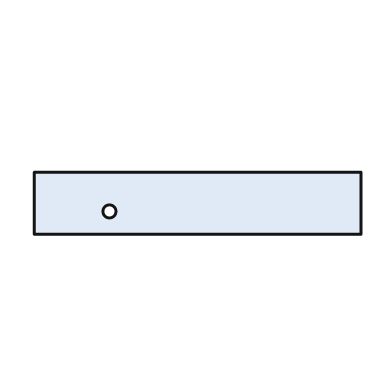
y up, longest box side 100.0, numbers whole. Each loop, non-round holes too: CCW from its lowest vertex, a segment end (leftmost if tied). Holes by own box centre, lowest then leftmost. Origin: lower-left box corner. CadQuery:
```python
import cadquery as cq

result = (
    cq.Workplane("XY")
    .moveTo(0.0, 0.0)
    .lineTo(100.0, 0.0)
    .lineTo(100.0, 19.0)
    .lineTo(0.0, 19.0)
    .close()
    .moveTo(23.0, 7.0)
    .circle(2.0)
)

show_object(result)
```